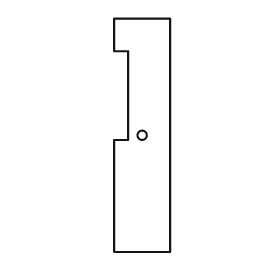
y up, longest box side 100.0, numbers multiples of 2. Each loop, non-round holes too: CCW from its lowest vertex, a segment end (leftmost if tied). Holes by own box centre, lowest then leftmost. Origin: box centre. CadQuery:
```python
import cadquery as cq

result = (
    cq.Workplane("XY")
    .moveTo(-12.0, -50.0)
    .lineTo(12.0, -50.0)
    .lineTo(12.0, 50.0)
    .lineTo(-12.0, 50.0)
    .lineTo(-12.0, 36.0)
    .lineTo(-6.0, 36.0)
    .lineTo(-6.0, -2.0)
    .lineTo(-12.0, -2.0)
    .close()
    .moveTo(0.0, 0.0)
    .circle(2.0)
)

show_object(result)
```